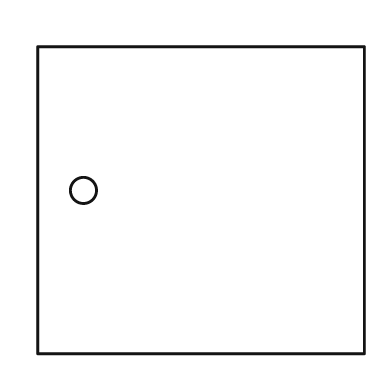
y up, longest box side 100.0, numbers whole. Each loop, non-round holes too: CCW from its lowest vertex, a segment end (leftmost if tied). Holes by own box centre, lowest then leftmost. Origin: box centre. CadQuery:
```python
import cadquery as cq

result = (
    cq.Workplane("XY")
    .moveTo(-50.0, -47.0)
    .lineTo(50.0, -47.0)
    .lineTo(50.0, 47.0)
    .lineTo(-50.0, 47.0)
    .close()
    .moveTo(-36.0, 3.0)
    .circle(4.0)
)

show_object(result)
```